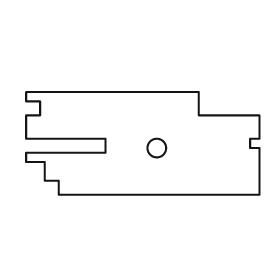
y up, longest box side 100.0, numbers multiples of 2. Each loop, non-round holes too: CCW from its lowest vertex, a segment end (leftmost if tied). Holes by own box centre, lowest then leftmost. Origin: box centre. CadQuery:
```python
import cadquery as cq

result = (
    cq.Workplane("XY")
    .moveTo(-36.0, -22.0)
    .lineTo(50.0, -22.0)
    .lineTo(50.0, -2.0)
    .lineTo(46.0, -2.0)
    .lineTo(46.0, 2.0)
    .lineTo(50.0, 2.0)
    .lineTo(50.0, 12.0)
    .lineTo(24.0, 12.0)
    .lineTo(24.0, 22.0)
    .lineTo(-50.0, 22.0)
    .lineTo(-50.0, 18.0)
    .lineTo(-44.0, 18.0)
    .lineTo(-44.0, 12.0)
    .lineTo(-50.0, 12.0)
    .lineTo(-50.0, 2.0)
    .lineTo(-16.0, 2.0)
    .lineTo(-16.0, -4.0)
    .lineTo(-50.0, -4.0)
    .lineTo(-50.0, -8.0)
    .lineTo(-42.0, -8.0)
    .lineTo(-42.0, -16.0)
    .lineTo(-36.0, -16.0)
    .close()
    .moveTo(6.0, -2.0)
    .circle(4.0)
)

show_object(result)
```